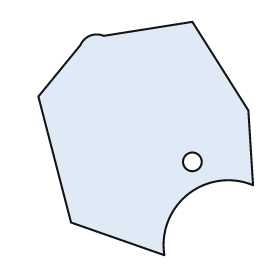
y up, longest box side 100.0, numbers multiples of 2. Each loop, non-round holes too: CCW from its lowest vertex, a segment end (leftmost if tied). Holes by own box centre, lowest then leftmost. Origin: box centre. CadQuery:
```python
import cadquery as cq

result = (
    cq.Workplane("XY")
    .moveTo(8.0, -50.0)
    .threePointArc((18.0, -24.0), (46.0, -20.0))
    .lineTo(44.0, 12.0)
    .lineTo(20.0, 50.0)
    .lineTo(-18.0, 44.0)
    .threePointArc((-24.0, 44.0), (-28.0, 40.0))
    .lineTo(-46.0, 18.0)
    .lineTo(-32.0, -36.0)
    .close()
    .moveTo(20.0, -10.0)
    .circle(4.0)
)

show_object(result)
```